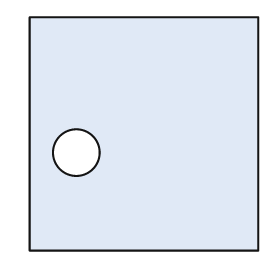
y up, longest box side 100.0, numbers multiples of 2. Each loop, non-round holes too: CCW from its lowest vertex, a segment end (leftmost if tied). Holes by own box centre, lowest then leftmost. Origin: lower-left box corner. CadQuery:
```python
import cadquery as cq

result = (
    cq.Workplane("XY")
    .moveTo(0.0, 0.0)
    .lineTo(98.0, 0.0)
    .lineTo(98.0, 100.0)
    .lineTo(0.0, 100.0)
    .close()
    .moveTo(20.0, 42.0)
    .circle(10.0)
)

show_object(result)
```